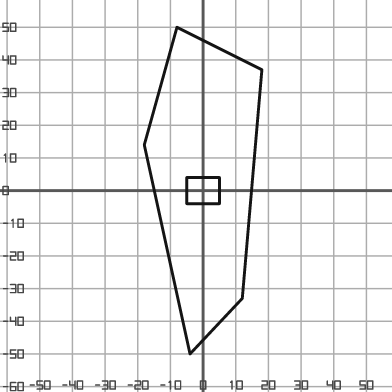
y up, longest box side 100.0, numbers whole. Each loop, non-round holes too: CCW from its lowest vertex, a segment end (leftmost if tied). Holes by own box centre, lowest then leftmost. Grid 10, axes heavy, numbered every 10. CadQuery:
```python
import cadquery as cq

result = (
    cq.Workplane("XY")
    .moveTo(-4.0, -50.0)
    .lineTo(12.0, -33.0)
    .lineTo(18.0, 37.0)
    .lineTo(-8.0, 50.0)
    .lineTo(-18.0, 14.0)
    .close()
    .moveTo(-5.0, -4.0)
    .lineTo(5.0, -4.0)
    .lineTo(5.0, 4.0)
    .lineTo(-5.0, 4.0)
    .close()
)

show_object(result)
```